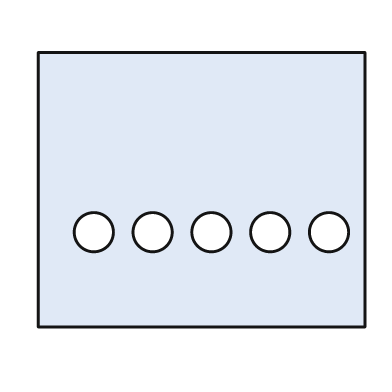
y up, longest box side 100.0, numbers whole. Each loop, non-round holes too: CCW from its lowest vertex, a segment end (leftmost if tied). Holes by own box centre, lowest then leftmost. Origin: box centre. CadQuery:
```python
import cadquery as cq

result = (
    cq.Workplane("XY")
    .moveTo(-50.0, -42.0)
    .lineTo(50.0, -42.0)
    .lineTo(50.0, 42.0)
    .lineTo(-50.0, 42.0)
    .close()
    .moveTo(-33.0, -13.0)
    .circle(6.0)
    .moveTo(-15.0, -13.0)
    .circle(6.0)
    .moveTo(3.0, -13.0)
    .circle(6.0)
    .moveTo(21.0, -13.0)
    .circle(6.0)
    .moveTo(39.0, -13.0)
    .circle(6.0)
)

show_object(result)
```